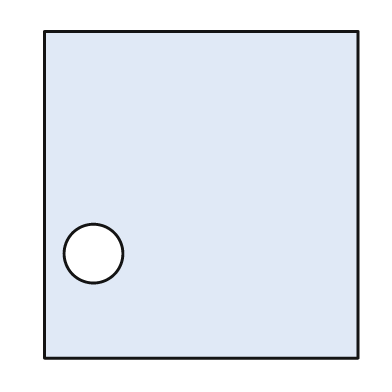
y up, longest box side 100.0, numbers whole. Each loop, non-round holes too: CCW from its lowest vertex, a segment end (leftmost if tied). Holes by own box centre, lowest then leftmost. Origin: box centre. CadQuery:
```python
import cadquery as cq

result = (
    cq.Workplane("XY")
    .moveTo(-48.0, -50.0)
    .lineTo(48.0, -50.0)
    .lineTo(48.0, 50.0)
    .lineTo(-48.0, 50.0)
    .close()
    .moveTo(-33.0, -18.0)
    .circle(9.0)
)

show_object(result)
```